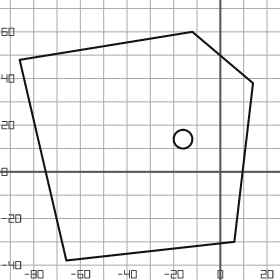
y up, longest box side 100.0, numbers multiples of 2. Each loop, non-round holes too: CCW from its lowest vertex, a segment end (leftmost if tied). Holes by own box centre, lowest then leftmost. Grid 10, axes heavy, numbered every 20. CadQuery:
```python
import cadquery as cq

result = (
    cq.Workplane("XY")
    .moveTo(-66.0, -38.0)
    .lineTo(6.0, -30.0)
    .lineTo(14.0, 38.0)
    .lineTo(-12.0, 60.0)
    .lineTo(-86.0, 48.0)
    .close()
    .moveTo(-16.0, 14.0)
    .circle(4.0)
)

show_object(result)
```